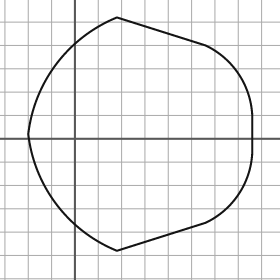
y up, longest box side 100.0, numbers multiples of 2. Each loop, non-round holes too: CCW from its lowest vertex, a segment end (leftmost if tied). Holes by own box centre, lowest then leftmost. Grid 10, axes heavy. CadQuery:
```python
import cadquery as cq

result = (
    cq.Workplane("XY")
    .moveTo(18.0, -48.0)
    .lineTo(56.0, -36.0)
    .threePointArc((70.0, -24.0), (76.0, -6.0))
    .lineTo(76.0, 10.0)
    .threePointArc((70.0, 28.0), (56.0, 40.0))
    .lineTo(18.0, 52.0)
    .threePointArc((-8.0, 32.0), (-20.0, 2.0))
    .threePointArc((-8.0, -28.0), (18.0, -48.0))
    .close()
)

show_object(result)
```